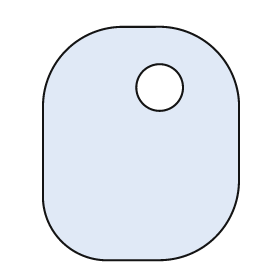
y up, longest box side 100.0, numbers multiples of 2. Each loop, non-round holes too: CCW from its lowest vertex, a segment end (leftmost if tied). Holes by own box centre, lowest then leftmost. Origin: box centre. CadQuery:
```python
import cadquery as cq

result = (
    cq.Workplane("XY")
    .moveTo(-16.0, -50.0)
    .lineTo(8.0, -50.0)
    .threePointArc((32.0, -40.0), (42.0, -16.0))
    .lineTo(42.0, 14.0)
    .threePointArc((32.0, 40.0), (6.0, 50.0))
    .lineTo(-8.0, 50.0)
    .threePointArc((-32.0, 40.0), (-42.0, 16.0))
    .lineTo(-42.0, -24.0)
    .threePointArc((-34.0, -42.0), (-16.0, -50.0))
    .close()
    .moveTo(8.0, 24.0)
    .circle(10.0)
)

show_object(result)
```